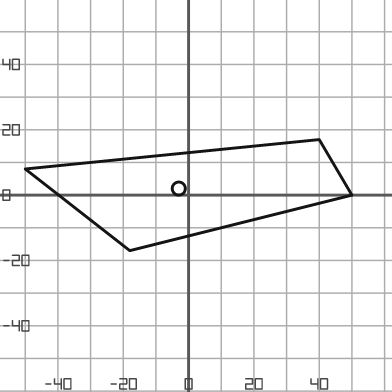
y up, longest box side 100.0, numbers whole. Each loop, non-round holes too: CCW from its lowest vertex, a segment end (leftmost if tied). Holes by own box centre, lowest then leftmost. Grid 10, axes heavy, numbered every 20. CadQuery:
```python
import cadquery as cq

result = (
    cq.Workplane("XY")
    .moveTo(-18.0, -17.0)
    .lineTo(50.0, 0.0)
    .lineTo(40.0, 17.0)
    .lineTo(-50.0, 8.0)
    .close()
    .moveTo(-3.0, 2.0)
    .circle(2.0)
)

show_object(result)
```